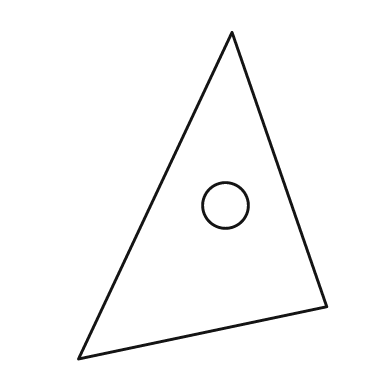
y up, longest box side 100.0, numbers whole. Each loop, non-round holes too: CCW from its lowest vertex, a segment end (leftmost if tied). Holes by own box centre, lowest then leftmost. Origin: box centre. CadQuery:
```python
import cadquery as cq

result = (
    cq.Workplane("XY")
    .moveTo(-38.0, -50.0)
    .lineTo(38.0, -34.0)
    .lineTo(9.0, 50.0)
    .close()
    .moveTo(7.0, -3.0)
    .circle(7.0)
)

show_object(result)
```